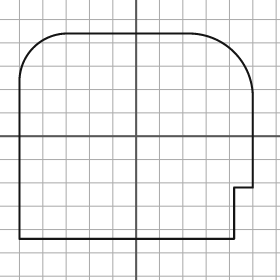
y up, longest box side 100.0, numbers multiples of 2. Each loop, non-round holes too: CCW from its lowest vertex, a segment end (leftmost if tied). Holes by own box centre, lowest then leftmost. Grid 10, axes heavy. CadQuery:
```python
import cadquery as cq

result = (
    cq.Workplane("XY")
    .moveTo(-50.0, -44.0)
    .lineTo(42.0, -44.0)
    .lineTo(42.0, -22.0)
    .lineTo(50.0, -22.0)
    .lineTo(50.0, 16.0)
    .threePointArc((42.0, 36.0), (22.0, 44.0))
    .lineTo(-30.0, 44.0)
    .threePointArc((-44.0, 38.0), (-50.0, 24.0))
    .close()
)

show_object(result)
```